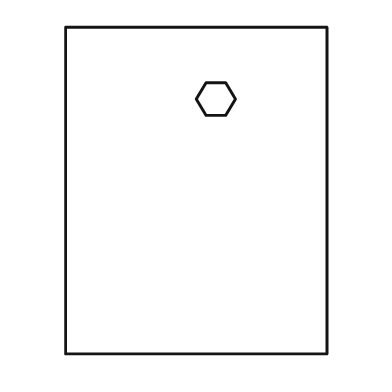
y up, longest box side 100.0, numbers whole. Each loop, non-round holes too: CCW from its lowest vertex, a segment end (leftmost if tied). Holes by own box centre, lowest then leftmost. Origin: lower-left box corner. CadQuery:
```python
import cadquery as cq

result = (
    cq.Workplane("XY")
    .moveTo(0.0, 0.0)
    .lineTo(80.0, 0.0)
    .lineTo(80.0, 100.0)
    .lineTo(0.0, 100.0)
    .close()
    .moveTo(43.0, 73.0)
    .lineTo(49.0, 73.0)
    .lineTo(52.0, 78.0)
    .lineTo(49.0, 83.0)
    .lineTo(43.0, 83.0)
    .lineTo(40.0, 78.0)
    .close()
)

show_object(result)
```